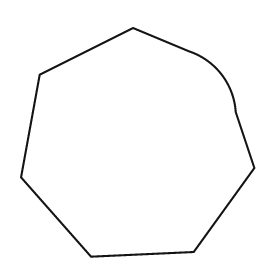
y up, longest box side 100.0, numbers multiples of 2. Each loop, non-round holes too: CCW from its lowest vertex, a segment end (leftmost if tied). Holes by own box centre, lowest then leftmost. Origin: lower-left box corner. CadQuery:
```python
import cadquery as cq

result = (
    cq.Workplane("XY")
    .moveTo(30.0, 0.0)
    .lineTo(74.0, 2.0)
    .lineTo(100.0, 38.0)
    .lineTo(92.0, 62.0)
    .threePointArc((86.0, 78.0), (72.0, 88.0))
    .lineTo(48.0, 98.0)
    .lineTo(8.0, 78.0)
    .lineTo(0.0, 34.0)
    .close()
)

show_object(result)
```